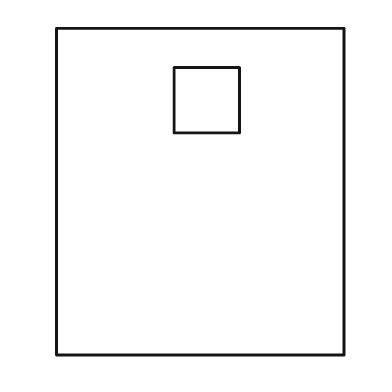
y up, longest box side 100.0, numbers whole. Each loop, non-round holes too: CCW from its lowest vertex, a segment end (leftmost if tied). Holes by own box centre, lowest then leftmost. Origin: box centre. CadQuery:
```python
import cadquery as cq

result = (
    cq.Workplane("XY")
    .moveTo(-44.0, -50.0)
    .lineTo(44.0, -50.0)
    .lineTo(44.0, 50.0)
    .lineTo(-44.0, 50.0)
    .close()
    .moveTo(-8.0, 18.0)
    .lineTo(12.0, 18.0)
    .lineTo(12.0, 38.0)
    .lineTo(-8.0, 38.0)
    .close()
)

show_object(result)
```